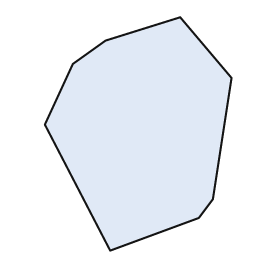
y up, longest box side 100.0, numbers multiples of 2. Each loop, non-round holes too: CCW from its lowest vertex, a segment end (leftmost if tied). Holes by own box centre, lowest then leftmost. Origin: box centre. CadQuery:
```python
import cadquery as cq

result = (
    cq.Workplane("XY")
    .moveTo(-12.0, -50.0)
    .lineTo(26.0, -36.0)
    .lineTo(32.0, -28.0)
    .lineTo(40.0, 24.0)
    .lineTo(18.0, 50.0)
    .lineTo(-14.0, 40.0)
    .lineTo(-28.0, 30.0)
    .lineTo(-40.0, 4.0)
    .close()
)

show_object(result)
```